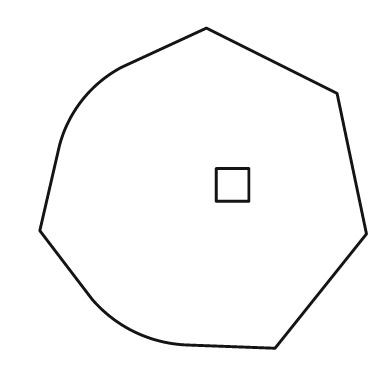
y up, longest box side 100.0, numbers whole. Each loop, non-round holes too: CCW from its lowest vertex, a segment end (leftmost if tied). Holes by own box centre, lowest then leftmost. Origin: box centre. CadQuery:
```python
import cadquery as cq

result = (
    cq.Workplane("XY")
    .moveTo(22.0, -49.0)
    .lineTo(50.0, -14.0)
    .lineTo(41.0, 29.0)
    .lineTo(1.0, 49.0)
    .lineTo(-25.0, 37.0)
    .threePointArc((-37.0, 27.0), (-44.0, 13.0))
    .lineTo(-50.0, -13.0)
    .lineTo(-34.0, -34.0)
    .threePointArc((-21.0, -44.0), (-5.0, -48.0))
    .close()
    .moveTo(4.0, -4.0)
    .lineTo(14.0, -4.0)
    .lineTo(14.0, 6.0)
    .lineTo(4.0, 6.0)
    .close()
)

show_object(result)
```